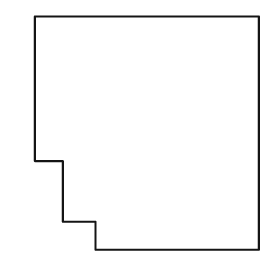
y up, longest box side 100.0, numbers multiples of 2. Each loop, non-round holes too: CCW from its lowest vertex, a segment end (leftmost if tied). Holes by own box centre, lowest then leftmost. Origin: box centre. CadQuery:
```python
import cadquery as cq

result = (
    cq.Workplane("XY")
    .moveTo(-22.0, -50.0)
    .lineTo(48.0, -50.0)
    .lineTo(48.0, 50.0)
    .lineTo(-48.0, 50.0)
    .lineTo(-48.0, -12.0)
    .lineTo(-36.0, -12.0)
    .lineTo(-36.0, -38.0)
    .lineTo(-22.0, -38.0)
    .close()
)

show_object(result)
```